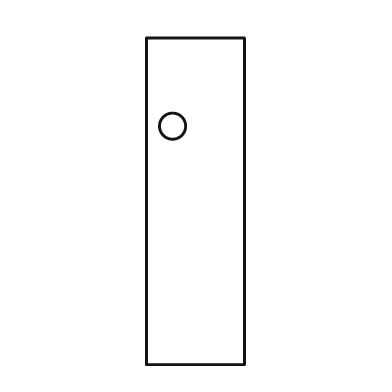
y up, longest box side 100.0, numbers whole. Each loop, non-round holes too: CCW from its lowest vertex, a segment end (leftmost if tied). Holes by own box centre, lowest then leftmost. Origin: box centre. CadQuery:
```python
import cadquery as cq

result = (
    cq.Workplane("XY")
    .moveTo(-15.0, -50.0)
    .lineTo(15.0, -50.0)
    .lineTo(15.0, 50.0)
    .lineTo(-15.0, 50.0)
    .close()
    .moveTo(-7.0, 23.0)
    .circle(4.0)
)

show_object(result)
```